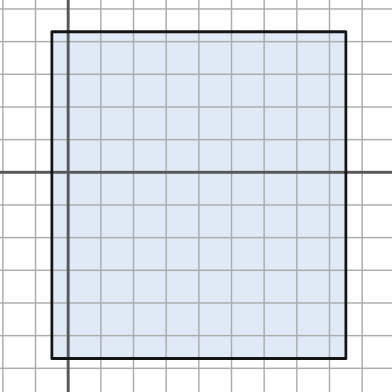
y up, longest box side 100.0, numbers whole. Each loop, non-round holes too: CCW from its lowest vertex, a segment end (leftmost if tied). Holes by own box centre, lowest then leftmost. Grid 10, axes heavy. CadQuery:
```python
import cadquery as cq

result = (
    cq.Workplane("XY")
    .moveTo(-5.0, -57.0)
    .lineTo(85.0, -57.0)
    .lineTo(85.0, 43.0)
    .lineTo(-5.0, 43.0)
    .close()
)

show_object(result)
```